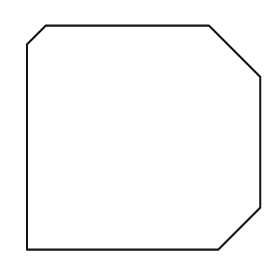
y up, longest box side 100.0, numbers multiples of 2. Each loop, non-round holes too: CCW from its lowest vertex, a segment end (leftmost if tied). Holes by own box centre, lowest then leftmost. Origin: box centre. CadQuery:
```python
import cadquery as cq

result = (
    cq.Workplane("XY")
    .moveTo(-50.0, -48.0)
    .lineTo(32.0, -48.0)
    .lineTo(50.0, -30.0)
    .lineTo(50.0, 26.0)
    .lineTo(28.0, 48.0)
    .lineTo(-42.0, 48.0)
    .lineTo(-50.0, 40.0)
    .close()
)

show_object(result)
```